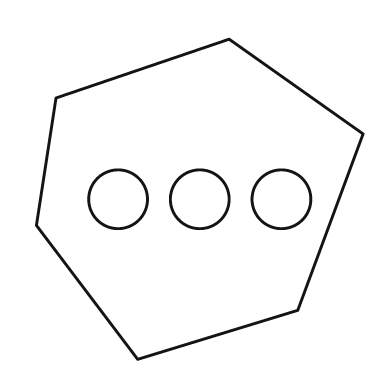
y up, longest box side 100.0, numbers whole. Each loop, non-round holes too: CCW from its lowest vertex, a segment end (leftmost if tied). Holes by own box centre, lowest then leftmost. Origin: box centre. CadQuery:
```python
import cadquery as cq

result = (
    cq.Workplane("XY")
    .moveTo(-19.0, -49.0)
    .lineTo(30.0, -34.0)
    .lineTo(50.0, 20.0)
    .lineTo(9.0, 49.0)
    .lineTo(-44.0, 31.0)
    .lineTo(-50.0, -8.0)
    .close()
    .moveTo(-25.0, 0.0)
    .circle(9.0)
    .moveTo(0.0, 0.0)
    .circle(9.0)
    .moveTo(25.0, 0.0)
    .circle(9.0)
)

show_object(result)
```